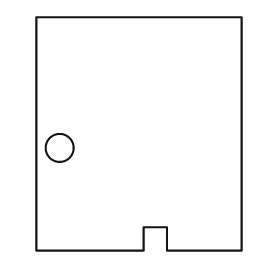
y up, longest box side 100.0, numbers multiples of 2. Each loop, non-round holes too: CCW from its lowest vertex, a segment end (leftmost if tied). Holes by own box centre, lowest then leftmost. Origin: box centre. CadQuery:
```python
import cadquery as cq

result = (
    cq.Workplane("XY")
    .moveTo(-44.0, -50.0)
    .lineTo(2.0, -50.0)
    .lineTo(2.0, -40.0)
    .lineTo(12.0, -40.0)
    .lineTo(12.0, -50.0)
    .lineTo(44.0, -50.0)
    .lineTo(44.0, 50.0)
    .lineTo(-44.0, 50.0)
    .close()
    .moveTo(-34.0, -6.0)
    .circle(6.0)
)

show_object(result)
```